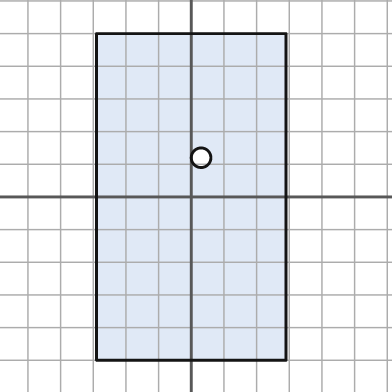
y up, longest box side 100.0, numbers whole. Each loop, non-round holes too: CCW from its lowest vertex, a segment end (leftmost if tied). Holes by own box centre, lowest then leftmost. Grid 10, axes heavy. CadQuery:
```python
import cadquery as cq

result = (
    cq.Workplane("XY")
    .moveTo(-29.0, -50.0)
    .lineTo(29.0, -50.0)
    .lineTo(29.0, 50.0)
    .lineTo(-29.0, 50.0)
    .close()
    .moveTo(3.0, 12.0)
    .circle(3.0)
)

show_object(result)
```